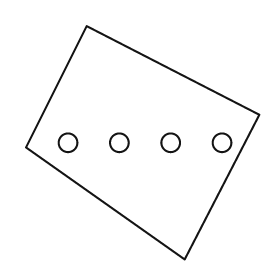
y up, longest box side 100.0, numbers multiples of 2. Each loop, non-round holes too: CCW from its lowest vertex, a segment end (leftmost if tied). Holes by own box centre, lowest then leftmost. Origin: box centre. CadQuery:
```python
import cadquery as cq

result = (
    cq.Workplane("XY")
    .moveTo(18.0, -50.0)
    .lineTo(50.0, 12.0)
    .lineTo(-24.0, 50.0)
    .lineTo(-50.0, -2.0)
    .close()
    .moveTo(-32.0, 0.0)
    .circle(4.0)
    .moveTo(-10.0, 0.0)
    .circle(4.0)
    .moveTo(12.0, 0.0)
    .circle(4.0)
    .moveTo(34.0, 0.0)
    .circle(4.0)
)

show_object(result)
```